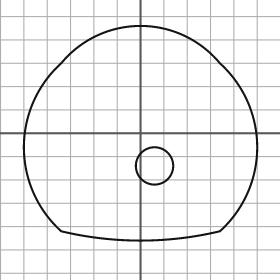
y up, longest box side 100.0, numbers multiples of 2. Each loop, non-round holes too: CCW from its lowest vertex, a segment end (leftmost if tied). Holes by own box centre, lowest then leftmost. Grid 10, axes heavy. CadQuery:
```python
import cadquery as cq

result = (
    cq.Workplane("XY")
    .moveTo(-34.0, -42.0)
    .threePointArc((0.0, -46.0), (34.0, -42.0))
    .threePointArc((50.0, -6.0), (34.0, 30.0))
    .threePointArc((0.0, 46.0), (-34.0, 30.0))
    .threePointArc((-50.0, -6.0), (-34.0, -42.0))
    .close()
    .moveTo(6.0, -14.0)
    .circle(8.0)
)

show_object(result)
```